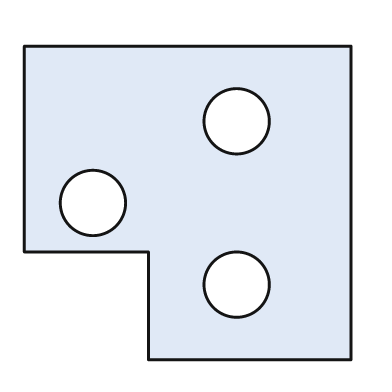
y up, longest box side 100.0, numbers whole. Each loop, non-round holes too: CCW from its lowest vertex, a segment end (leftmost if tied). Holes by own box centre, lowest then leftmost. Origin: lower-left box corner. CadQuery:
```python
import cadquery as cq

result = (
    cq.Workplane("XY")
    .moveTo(38.0, 0.0)
    .lineTo(100.0, 0.0)
    .lineTo(100.0, 96.0)
    .lineTo(0.0, 96.0)
    .lineTo(0.0, 33.0)
    .lineTo(38.0, 33.0)
    .close()
    .moveTo(65.0, 23.0)
    .circle(10.0)
    .moveTo(21.0, 48.0)
    .circle(10.0)
    .moveTo(65.0, 73.0)
    .circle(10.0)
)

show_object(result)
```